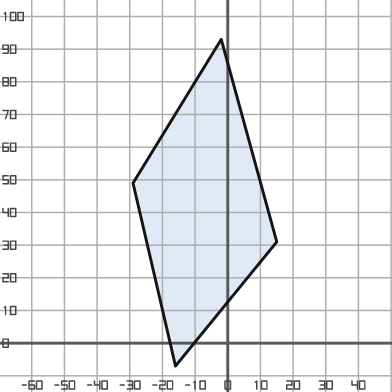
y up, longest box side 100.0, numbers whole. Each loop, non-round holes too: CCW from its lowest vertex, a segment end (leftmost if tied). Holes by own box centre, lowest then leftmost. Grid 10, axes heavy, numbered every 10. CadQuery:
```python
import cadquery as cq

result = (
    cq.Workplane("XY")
    .moveTo(-16.0, -7.0)
    .lineTo(15.0, 31.0)
    .lineTo(-2.0, 93.0)
    .lineTo(-29.0, 49.0)
    .close()
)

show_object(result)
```